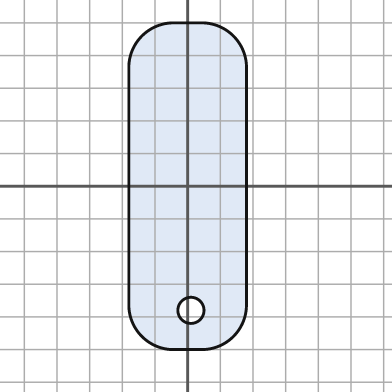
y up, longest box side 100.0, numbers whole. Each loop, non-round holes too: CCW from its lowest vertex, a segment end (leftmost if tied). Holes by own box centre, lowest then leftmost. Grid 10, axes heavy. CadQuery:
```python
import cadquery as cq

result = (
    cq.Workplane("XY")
    .moveTo(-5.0, -50.0)
    .lineTo(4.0, -50.0)
    .threePointArc((14.0, -46.0), (18.0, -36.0))
    .lineTo(18.0, 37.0)
    .threePointArc((14.0, 46.0), (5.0, 50.0))
    .lineTo(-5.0, 50.0)
    .threePointArc((-14.0, 46.0), (-18.0, 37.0))
    .lineTo(-18.0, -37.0)
    .threePointArc((-14.0, -46.0), (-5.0, -50.0))
    .close()
    .moveTo(1.0, -38.0)
    .circle(4.0)
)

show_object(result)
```